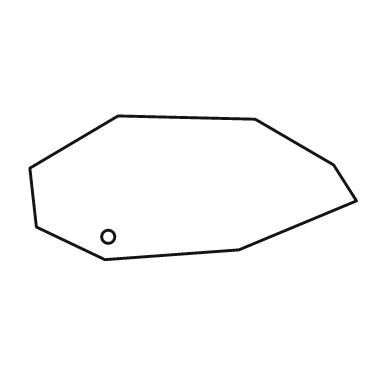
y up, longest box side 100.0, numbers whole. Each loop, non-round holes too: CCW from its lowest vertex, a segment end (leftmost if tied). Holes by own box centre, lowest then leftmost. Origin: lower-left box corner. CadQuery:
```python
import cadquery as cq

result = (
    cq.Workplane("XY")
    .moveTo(23.0, 0.0)
    .lineTo(64.0, 3.0)
    .lineTo(100.0, 18.0)
    .lineTo(93.0, 29.0)
    .lineTo(69.0, 43.0)
    .lineTo(27.0, 44.0)
    .lineTo(0.0, 28.0)
    .lineTo(2.0, 10.0)
    .close()
    .moveTo(24.0, 7.0)
    .circle(2.0)
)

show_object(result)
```